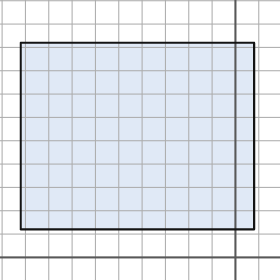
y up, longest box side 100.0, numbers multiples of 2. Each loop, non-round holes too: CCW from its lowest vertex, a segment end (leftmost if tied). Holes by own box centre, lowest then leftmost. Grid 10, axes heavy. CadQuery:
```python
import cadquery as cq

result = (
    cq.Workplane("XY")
    .moveTo(-92.0, 12.0)
    .lineTo(8.0, 12.0)
    .lineTo(8.0, 92.0)
    .lineTo(-92.0, 92.0)
    .close()
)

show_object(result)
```